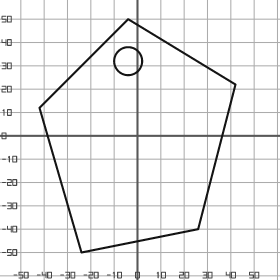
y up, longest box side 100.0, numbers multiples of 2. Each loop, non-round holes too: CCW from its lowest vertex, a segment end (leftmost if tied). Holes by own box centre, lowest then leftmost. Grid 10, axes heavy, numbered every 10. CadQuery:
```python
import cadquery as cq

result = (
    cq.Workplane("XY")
    .moveTo(-24.0, -50.0)
    .lineTo(26.0, -40.0)
    .lineTo(42.0, 22.0)
    .lineTo(-4.0, 50.0)
    .lineTo(-42.0, 12.0)
    .close()
    .moveTo(-4.0, 32.0)
    .circle(6.0)
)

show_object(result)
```